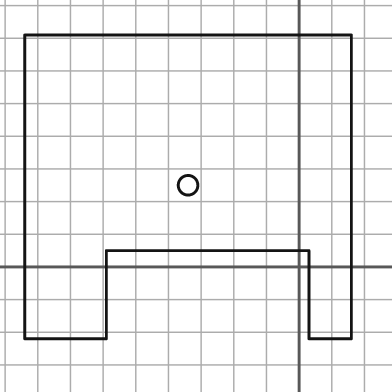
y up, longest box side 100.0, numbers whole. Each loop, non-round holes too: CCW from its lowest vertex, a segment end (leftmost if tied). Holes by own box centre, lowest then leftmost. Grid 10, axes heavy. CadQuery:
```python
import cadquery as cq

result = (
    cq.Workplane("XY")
    .moveTo(-84.0, -22.0)
    .lineTo(-59.0, -22.0)
    .lineTo(-59.0, 5.0)
    .lineTo(3.0, 5.0)
    .lineTo(3.0, -22.0)
    .lineTo(16.0, -22.0)
    .lineTo(16.0, 71.0)
    .lineTo(-84.0, 71.0)
    .close()
    .moveTo(-34.0, 25.0)
    .circle(3.0)
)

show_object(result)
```